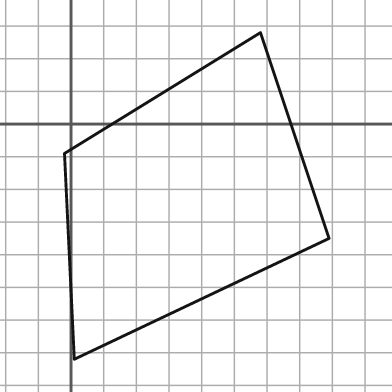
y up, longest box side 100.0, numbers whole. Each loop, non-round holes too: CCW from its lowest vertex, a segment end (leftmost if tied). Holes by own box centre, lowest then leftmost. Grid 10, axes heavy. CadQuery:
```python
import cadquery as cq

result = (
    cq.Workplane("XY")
    .moveTo(1.0, -72.0)
    .lineTo(79.0, -35.0)
    .lineTo(58.0, 28.0)
    .lineTo(-2.0, -9.0)
    .close()
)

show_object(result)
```